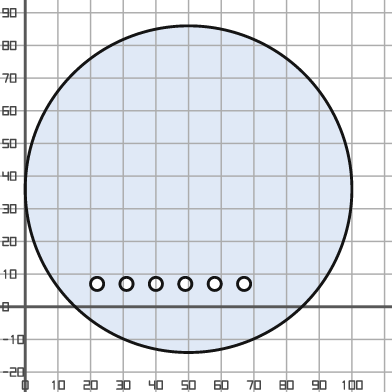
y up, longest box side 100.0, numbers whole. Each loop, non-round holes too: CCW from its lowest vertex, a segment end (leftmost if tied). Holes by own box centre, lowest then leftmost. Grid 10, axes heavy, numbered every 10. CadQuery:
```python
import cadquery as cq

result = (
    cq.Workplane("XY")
    .moveTo(50.0, 36.0)
    .circle(50.0)
    .moveTo(22.0, 7.0)
    .circle(2.0)
    .moveTo(31.0, 7.0)
    .circle(2.0)
    .moveTo(40.0, 7.0)
    .circle(2.0)
    .moveTo(49.0, 7.0)
    .circle(2.0)
    .moveTo(58.0, 7.0)
    .circle(2.0)
    .moveTo(67.0, 7.0)
    .circle(2.0)
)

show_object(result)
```